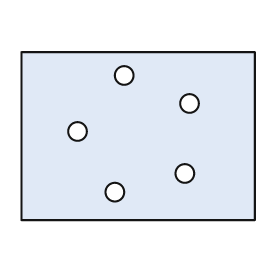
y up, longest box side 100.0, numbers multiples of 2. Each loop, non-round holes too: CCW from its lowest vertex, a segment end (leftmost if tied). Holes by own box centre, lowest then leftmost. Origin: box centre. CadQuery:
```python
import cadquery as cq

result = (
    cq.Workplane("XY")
    .moveTo(-50.0, -36.0)
    .lineTo(50.0, -36.0)
    .lineTo(50.0, 36.0)
    .lineTo(-50.0, 36.0)
    .close()
    .moveTo(-10.0, -24.0)
    .circle(4.0)
    .moveTo(20.0, -16.0)
    .circle(4.0)
    .moveTo(-26.0, 2.0)
    .circle(4.0)
    .moveTo(22.0, 14.0)
    .circle(4.0)
    .moveTo(-6.0, 26.0)
    .circle(4.0)
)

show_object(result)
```